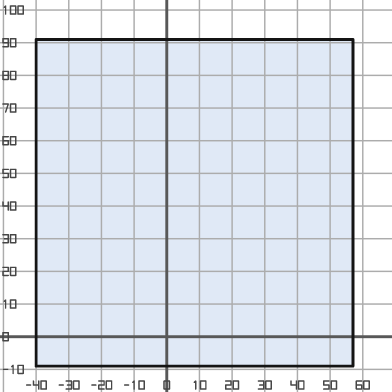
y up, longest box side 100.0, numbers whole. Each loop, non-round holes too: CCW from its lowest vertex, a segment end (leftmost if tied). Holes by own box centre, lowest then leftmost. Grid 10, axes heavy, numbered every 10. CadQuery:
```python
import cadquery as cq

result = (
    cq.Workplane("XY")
    .moveTo(-40.0, -9.0)
    .lineTo(57.0, -9.0)
    .lineTo(57.0, 91.0)
    .lineTo(-40.0, 91.0)
    .close()
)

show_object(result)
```